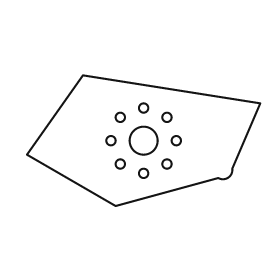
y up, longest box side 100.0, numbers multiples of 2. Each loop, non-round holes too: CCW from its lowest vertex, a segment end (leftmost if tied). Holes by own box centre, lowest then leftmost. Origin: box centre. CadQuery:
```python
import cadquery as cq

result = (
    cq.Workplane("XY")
    .moveTo(-12.0, -28.0)
    .lineTo(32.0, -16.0)
    .threePointArc((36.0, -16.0), (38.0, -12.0))
    .lineTo(50.0, 16.0)
    .lineTo(-26.0, 28.0)
    .lineTo(-50.0, -6.0)
    .close()
    .moveTo(0.0, -14.0)
    .circle(2.0)
    .moveTo(-10.0, -10.0)
    .circle(2.0)
    .moveTo(10.0, -10.0)
    .circle(2.0)
    .moveTo(-14.0, 0.0)
    .circle(2.0)
    .moveTo(0.0, 0.0)
    .circle(6.0)
    .moveTo(14.0, 0.0)
    .circle(2.0)
    .moveTo(-10.0, 10.0)
    .circle(2.0)
    .moveTo(10.0, 10.0)
    .circle(2.0)
    .moveTo(0.0, 14.0)
    .circle(2.0)
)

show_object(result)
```